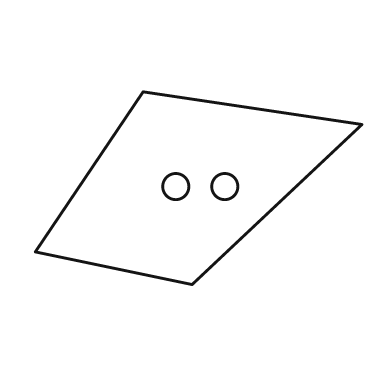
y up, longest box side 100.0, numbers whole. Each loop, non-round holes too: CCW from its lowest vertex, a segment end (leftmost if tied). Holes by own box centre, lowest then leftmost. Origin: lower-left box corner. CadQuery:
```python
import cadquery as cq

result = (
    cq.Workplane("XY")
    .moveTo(48.0, 0.0)
    .lineTo(100.0, 49.0)
    .lineTo(33.0, 59.0)
    .lineTo(0.0, 10.0)
    .close()
    .moveTo(43.0, 30.0)
    .circle(4.0)
    .moveTo(58.0, 30.0)
    .circle(4.0)
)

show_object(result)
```